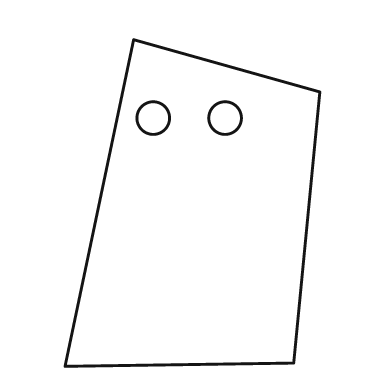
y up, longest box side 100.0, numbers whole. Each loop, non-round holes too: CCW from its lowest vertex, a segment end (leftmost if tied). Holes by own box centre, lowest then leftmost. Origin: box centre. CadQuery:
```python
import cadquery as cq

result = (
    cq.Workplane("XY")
    .moveTo(-39.0, -50.0)
    .lineTo(31.0, -49.0)
    .lineTo(39.0, 34.0)
    .lineTo(-18.0, 50.0)
    .close()
    .moveTo(-12.0, 26.0)
    .circle(5.0)
    .moveTo(10.0, 26.0)
    .circle(5.0)
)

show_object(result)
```